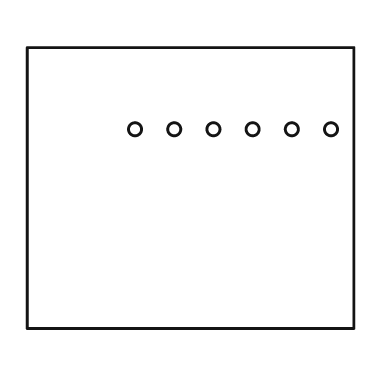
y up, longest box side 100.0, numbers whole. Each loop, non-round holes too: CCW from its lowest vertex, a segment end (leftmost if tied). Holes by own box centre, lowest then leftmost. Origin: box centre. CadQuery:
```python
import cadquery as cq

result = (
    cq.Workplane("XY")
    .moveTo(-50.0, -43.0)
    .lineTo(50.0, -43.0)
    .lineTo(50.0, 43.0)
    .lineTo(-50.0, 43.0)
    .close()
    .moveTo(-17.0, 18.0)
    .circle(2.0)
    .moveTo(-5.0, 18.0)
    .circle(2.0)
    .moveTo(7.0, 18.0)
    .circle(2.0)
    .moveTo(19.0, 18.0)
    .circle(2.0)
    .moveTo(31.0, 18.0)
    .circle(2.0)
    .moveTo(43.0, 18.0)
    .circle(2.0)
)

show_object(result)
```